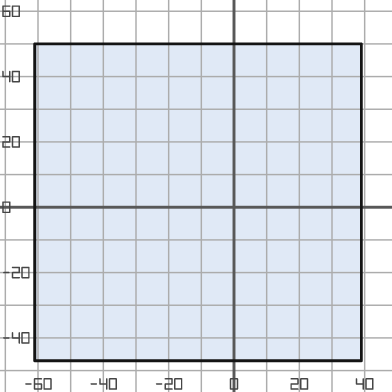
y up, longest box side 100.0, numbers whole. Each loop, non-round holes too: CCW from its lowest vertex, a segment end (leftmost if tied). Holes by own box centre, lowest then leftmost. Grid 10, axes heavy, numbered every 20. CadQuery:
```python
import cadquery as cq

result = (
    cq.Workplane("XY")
    .moveTo(-61.0, -47.0)
    .lineTo(39.0, -47.0)
    .lineTo(39.0, 50.0)
    .lineTo(-61.0, 50.0)
    .close()
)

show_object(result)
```